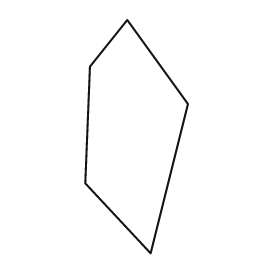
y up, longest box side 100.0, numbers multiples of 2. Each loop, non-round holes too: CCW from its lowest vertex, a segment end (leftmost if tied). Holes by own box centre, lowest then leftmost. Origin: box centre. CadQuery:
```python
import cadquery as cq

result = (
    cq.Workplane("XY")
    .moveTo(6.0, -50.0)
    .lineTo(22.0, 14.0)
    .lineTo(-4.0, 50.0)
    .lineTo(-20.0, 30.0)
    .lineTo(-22.0, -20.0)
    .close()
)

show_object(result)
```